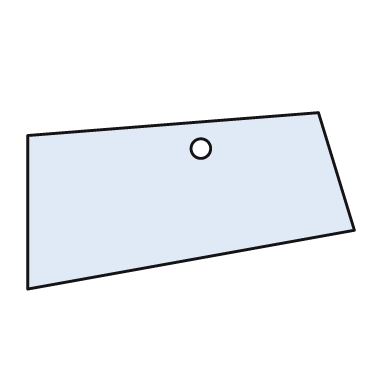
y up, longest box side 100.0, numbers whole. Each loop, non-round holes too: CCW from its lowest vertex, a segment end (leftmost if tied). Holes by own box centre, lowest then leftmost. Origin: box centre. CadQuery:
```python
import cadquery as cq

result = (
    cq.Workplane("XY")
    .moveTo(-50.0, -27.0)
    .lineTo(50.0, -9.0)
    .lineTo(39.0, 27.0)
    .lineTo(-50.0, 20.0)
    .close()
    .moveTo(3.0, 16.0)
    .circle(3.0)
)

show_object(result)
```